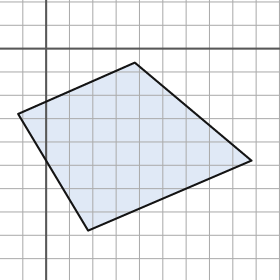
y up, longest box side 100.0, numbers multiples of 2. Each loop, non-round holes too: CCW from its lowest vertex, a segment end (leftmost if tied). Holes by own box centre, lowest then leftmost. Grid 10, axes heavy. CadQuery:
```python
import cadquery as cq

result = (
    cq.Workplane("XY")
    .moveTo(18.0, -78.0)
    .lineTo(88.0, -48.0)
    .lineTo(38.0, -6.0)
    .lineTo(-12.0, -28.0)
    .close()
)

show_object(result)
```